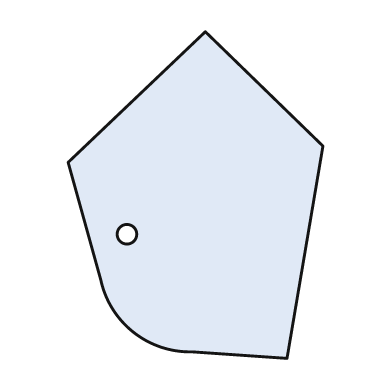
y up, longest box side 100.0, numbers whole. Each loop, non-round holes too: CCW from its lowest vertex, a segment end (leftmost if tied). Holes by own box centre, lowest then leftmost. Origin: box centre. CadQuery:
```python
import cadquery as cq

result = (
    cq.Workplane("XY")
    .moveTo(28.0, -50.0)
    .lineTo(39.0, 15.0)
    .lineTo(3.0, 50.0)
    .lineTo(-39.0, 10.0)
    .lineTo(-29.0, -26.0)
    .threePointArc((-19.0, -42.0), (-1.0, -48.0))
    .close()
    .moveTo(-21.0, -12.0)
    .circle(3.0)
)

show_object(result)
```